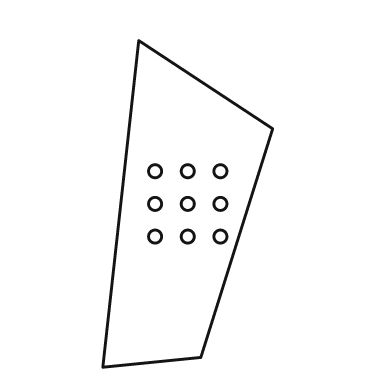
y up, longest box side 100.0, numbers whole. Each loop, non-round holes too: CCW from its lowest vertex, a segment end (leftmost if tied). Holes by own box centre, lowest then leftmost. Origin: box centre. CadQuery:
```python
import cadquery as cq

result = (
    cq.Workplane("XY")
    .moveTo(-26.0, -50.0)
    .lineTo(4.0, -47.0)
    .lineTo(26.0, 23.0)
    .lineTo(-15.0, 50.0)
    .close()
    .moveTo(-10.0, -10.0)
    .circle(2.0)
    .moveTo(0.0, -10.0)
    .circle(2.0)
    .moveTo(10.0, -10.0)
    .circle(2.0)
    .moveTo(-10.0, 0.0)
    .circle(2.0)
    .moveTo(0.0, 0.0)
    .circle(2.0)
    .moveTo(10.0, 0.0)
    .circle(2.0)
    .moveTo(-10.0, 10.0)
    .circle(2.0)
    .moveTo(0.0, 10.0)
    .circle(2.0)
    .moveTo(10.0, 10.0)
    .circle(2.0)
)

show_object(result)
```